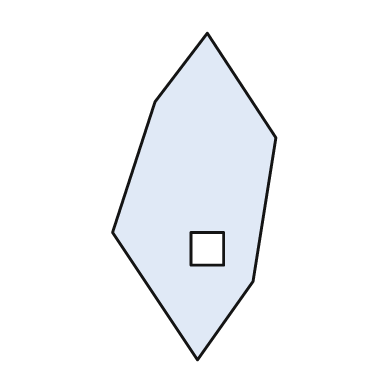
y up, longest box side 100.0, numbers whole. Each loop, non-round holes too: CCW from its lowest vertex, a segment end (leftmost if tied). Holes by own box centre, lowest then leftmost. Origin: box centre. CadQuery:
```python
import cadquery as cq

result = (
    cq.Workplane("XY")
    .moveTo(1.0, -50.0)
    .lineTo(18.0, -26.0)
    .lineTo(25.0, 18.0)
    .lineTo(4.0, 50.0)
    .lineTo(-12.0, 29.0)
    .lineTo(-25.0, -11.0)
    .close()
    .moveTo(-1.0, -21.0)
    .lineTo(9.0, -21.0)
    .lineTo(9.0, -11.0)
    .lineTo(-1.0, -11.0)
    .close()
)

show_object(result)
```